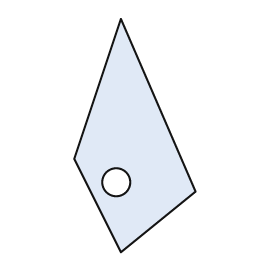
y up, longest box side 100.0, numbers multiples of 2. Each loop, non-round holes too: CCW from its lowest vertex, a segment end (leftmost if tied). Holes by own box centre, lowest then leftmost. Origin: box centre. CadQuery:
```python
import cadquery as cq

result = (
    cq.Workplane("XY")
    .moveTo(-6.0, -50.0)
    .lineTo(26.0, -24.0)
    .lineTo(-6.0, 50.0)
    .lineTo(-26.0, -10.0)
    .close()
    .moveTo(-8.0, -20.0)
    .circle(6.0)
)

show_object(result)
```